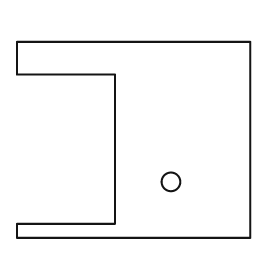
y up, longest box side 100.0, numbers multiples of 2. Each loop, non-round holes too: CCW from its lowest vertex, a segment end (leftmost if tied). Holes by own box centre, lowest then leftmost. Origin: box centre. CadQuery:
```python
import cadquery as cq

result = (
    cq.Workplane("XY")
    .moveTo(-50.0, -42.0)
    .lineTo(50.0, -42.0)
    .lineTo(50.0, 42.0)
    .lineTo(-50.0, 42.0)
    .lineTo(-50.0, 28.0)
    .lineTo(-8.0, 28.0)
    .lineTo(-8.0, -36.0)
    .lineTo(-50.0, -36.0)
    .close()
    .moveTo(16.0, -18.0)
    .circle(4.0)
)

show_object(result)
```